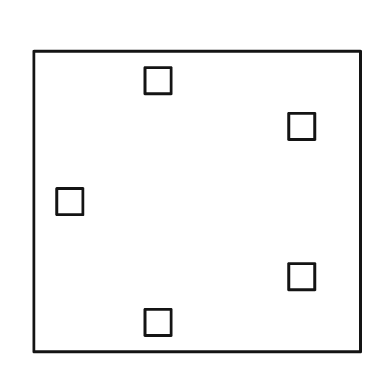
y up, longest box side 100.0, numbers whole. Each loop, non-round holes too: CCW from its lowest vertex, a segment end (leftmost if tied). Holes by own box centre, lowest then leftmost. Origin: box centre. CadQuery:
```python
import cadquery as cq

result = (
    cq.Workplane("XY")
    .moveTo(-50.0, -46.0)
    .lineTo(50.0, -46.0)
    .lineTo(50.0, 46.0)
    .lineTo(-50.0, 46.0)
    .close()
    .moveTo(-16.0, -41.0)
    .lineTo(-8.0, -41.0)
    .lineTo(-8.0, -33.0)
    .lineTo(-16.0, -33.0)
    .close()
    .moveTo(28.0, -27.0)
    .lineTo(36.0, -27.0)
    .lineTo(36.0, -19.0)
    .lineTo(28.0, -19.0)
    .close()
    .moveTo(-43.0, -4.0)
    .lineTo(-35.0, -4.0)
    .lineTo(-35.0, 4.0)
    .lineTo(-43.0, 4.0)
    .close()
    .moveTo(28.0, 19.0)
    .lineTo(36.0, 19.0)
    .lineTo(36.0, 27.0)
    .lineTo(28.0, 27.0)
    .close()
    .moveTo(-16.0, 33.0)
    .lineTo(-8.0, 33.0)
    .lineTo(-8.0, 41.0)
    .lineTo(-16.0, 41.0)
    .close()
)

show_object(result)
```